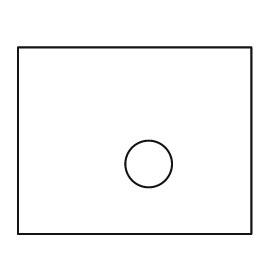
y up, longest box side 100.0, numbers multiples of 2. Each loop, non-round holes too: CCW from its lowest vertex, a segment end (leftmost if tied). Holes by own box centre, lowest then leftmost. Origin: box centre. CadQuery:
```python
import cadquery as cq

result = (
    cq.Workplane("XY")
    .moveTo(-50.0, -40.0)
    .lineTo(50.0, -40.0)
    .lineTo(50.0, 40.0)
    .lineTo(-50.0, 40.0)
    .close()
    .moveTo(6.0, -10.0)
    .circle(10.0)
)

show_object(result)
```